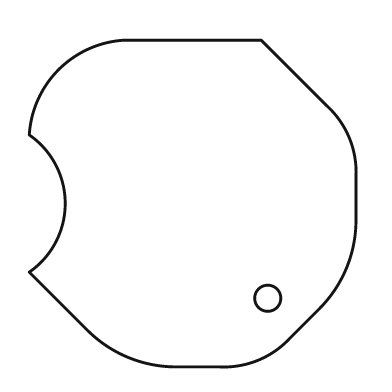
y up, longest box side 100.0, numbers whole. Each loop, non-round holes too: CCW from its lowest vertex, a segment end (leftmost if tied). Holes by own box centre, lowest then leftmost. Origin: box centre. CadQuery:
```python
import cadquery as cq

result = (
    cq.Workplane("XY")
    .moveTo(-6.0, -50.0)
    .lineTo(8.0, -50.0)
    .threePointArc((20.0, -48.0), (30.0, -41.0))
    .lineTo(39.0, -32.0)
    .threePointArc((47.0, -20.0), (50.0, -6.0))
    .lineTo(50.0, 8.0)
    .threePointArc((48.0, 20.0), (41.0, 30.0))
    .lineTo(21.0, 50.0)
    .lineTo(-21.0, 50.0)
    .threePointArc((-41.0, 41.0), (-50.0, 21.0))
    .threePointArc((-39.0, 0.0), (-50.0, -21.0))
    .lineTo(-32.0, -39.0)
    .threePointArc((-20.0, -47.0), (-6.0, -50.0))
    .close()
    .moveTo(23.0, -29.0)
    .circle(4.0)
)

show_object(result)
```